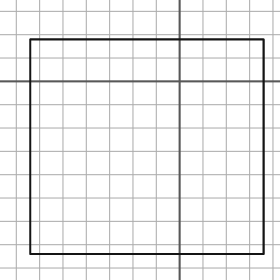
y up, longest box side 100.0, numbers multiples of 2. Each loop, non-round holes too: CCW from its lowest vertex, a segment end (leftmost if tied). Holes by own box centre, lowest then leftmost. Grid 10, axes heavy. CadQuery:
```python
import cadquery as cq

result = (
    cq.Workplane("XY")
    .moveTo(-64.0, -74.0)
    .lineTo(36.0, -74.0)
    .lineTo(36.0, 18.0)
    .lineTo(-64.0, 18.0)
    .close()
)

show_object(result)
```